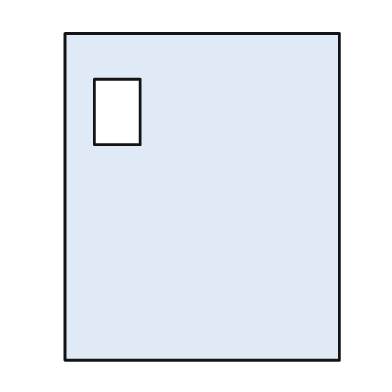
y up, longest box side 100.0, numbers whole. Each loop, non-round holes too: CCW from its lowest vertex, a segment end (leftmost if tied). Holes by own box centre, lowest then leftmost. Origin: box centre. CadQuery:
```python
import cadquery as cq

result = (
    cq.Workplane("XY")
    .moveTo(-42.0, -50.0)
    .lineTo(42.0, -50.0)
    .lineTo(42.0, 50.0)
    .lineTo(-42.0, 50.0)
    .close()
    .moveTo(-33.0, 16.0)
    .lineTo(-19.0, 16.0)
    .lineTo(-19.0, 36.0)
    .lineTo(-33.0, 36.0)
    .close()
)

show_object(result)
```